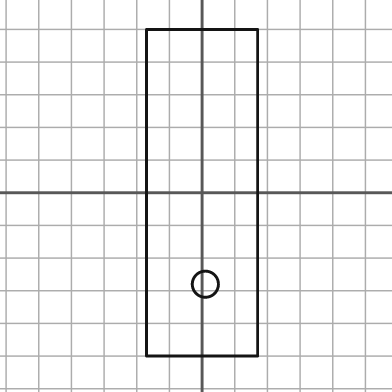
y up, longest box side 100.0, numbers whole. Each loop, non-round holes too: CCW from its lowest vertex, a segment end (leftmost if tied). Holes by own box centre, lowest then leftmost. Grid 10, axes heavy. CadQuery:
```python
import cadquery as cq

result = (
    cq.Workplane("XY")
    .moveTo(-17.0, -50.0)
    .lineTo(17.0, -50.0)
    .lineTo(17.0, 50.0)
    .lineTo(-17.0, 50.0)
    .close()
    .moveTo(1.0, -28.0)
    .circle(4.0)
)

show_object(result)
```